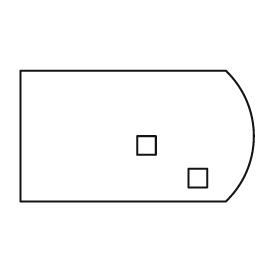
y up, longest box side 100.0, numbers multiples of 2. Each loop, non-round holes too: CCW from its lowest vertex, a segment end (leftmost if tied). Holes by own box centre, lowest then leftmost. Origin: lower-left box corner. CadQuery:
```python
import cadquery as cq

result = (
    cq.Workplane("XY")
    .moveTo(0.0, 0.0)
    .lineTo(88.0, 0.0)
    .threePointArc((100.0, 28.0), (88.0, 56.0))
    .lineTo(0.0, 56.0)
    .close()
    .moveTo(72.0, 6.0)
    .lineTo(80.0, 6.0)
    .lineTo(80.0, 14.0)
    .lineTo(72.0, 14.0)
    .close()
    .moveTo(50.0, 20.0)
    .lineTo(58.0, 20.0)
    .lineTo(58.0, 28.0)
    .lineTo(50.0, 28.0)
    .close()
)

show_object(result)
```